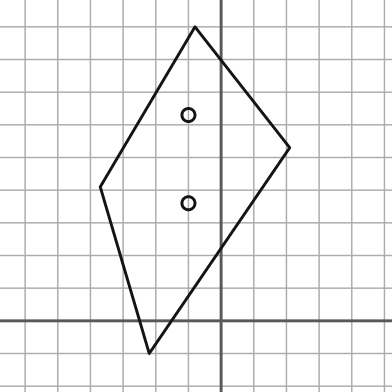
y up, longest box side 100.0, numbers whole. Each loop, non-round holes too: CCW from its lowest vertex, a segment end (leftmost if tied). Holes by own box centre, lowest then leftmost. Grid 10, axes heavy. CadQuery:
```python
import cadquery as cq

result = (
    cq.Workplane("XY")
    .moveTo(-22.0, -10.0)
    .lineTo(21.0, 53.0)
    .lineTo(-8.0, 90.0)
    .lineTo(-37.0, 41.0)
    .close()
    .moveTo(-10.0, 36.0)
    .circle(2.0)
    .moveTo(-10.0, 63.0)
    .circle(2.0)
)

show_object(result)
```